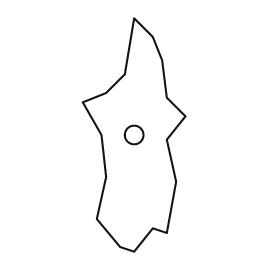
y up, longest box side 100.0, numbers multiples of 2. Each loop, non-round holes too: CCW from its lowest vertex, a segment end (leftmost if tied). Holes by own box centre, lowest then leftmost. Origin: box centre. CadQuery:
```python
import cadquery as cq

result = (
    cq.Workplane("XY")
    .moveTo(0.0, -50.0)
    .lineTo(8.0, -40.0)
    .lineTo(14.0, -42.0)
    .lineTo(18.0, -20.0)
    .lineTo(14.0, -2.0)
    .lineTo(22.0, 8.0)
    .lineTo(14.0, 16.0)
    .lineTo(12.0, 32.0)
    .lineTo(8.0, 42.0)
    .lineTo(0.0, 50.0)
    .lineTo(-4.0, 26.0)
    .lineTo(-12.0, 18.0)
    .lineTo(-22.0, 14.0)
    .lineTo(-14.0, 0.0)
    .lineTo(-12.0, -18.0)
    .lineTo(-16.0, -36.0)
    .lineTo(-6.0, -48.0)
    .close()
    .moveTo(0.0, 0.0)
    .circle(4.0)
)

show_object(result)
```